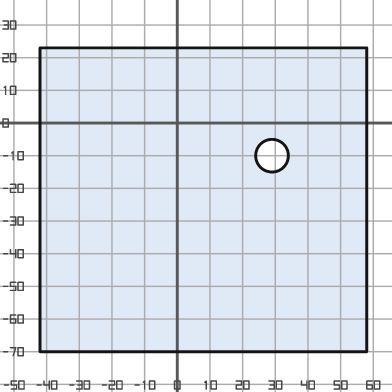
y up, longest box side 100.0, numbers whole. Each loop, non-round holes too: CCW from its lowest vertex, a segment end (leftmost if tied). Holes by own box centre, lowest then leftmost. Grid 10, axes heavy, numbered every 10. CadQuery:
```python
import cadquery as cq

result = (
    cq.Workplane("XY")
    .moveTo(-42.0, -70.0)
    .lineTo(58.0, -70.0)
    .lineTo(58.0, 23.0)
    .lineTo(-42.0, 23.0)
    .close()
    .moveTo(29.0, -10.0)
    .circle(5.0)
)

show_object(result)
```